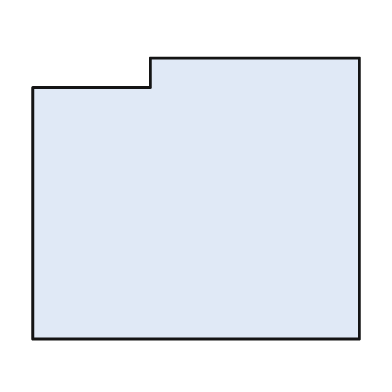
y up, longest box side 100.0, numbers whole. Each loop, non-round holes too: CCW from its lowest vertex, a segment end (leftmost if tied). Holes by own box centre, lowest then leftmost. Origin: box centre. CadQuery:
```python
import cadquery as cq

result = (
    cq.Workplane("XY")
    .moveTo(-50.0, -43.0)
    .lineTo(50.0, -43.0)
    .lineTo(50.0, 43.0)
    .lineTo(-14.0, 43.0)
    .lineTo(-14.0, 34.0)
    .lineTo(-50.0, 34.0)
    .close()
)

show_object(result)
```